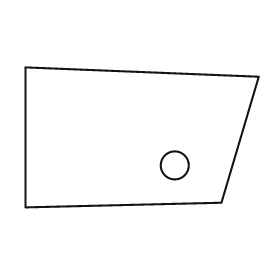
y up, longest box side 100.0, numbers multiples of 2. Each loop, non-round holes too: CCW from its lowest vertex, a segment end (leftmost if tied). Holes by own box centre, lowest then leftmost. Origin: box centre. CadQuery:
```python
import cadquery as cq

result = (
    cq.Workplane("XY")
    .moveTo(-50.0, -30.0)
    .lineTo(34.0, -28.0)
    .lineTo(50.0, 26.0)
    .lineTo(-50.0, 30.0)
    .close()
    .moveTo(14.0, -12.0)
    .circle(6.0)
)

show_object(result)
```